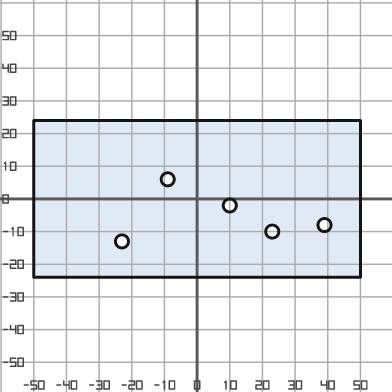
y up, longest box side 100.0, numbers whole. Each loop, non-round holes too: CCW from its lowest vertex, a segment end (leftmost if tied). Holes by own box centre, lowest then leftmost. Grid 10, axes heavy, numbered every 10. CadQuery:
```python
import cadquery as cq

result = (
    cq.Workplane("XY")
    .moveTo(-50.0, -24.0)
    .lineTo(50.0, -24.0)
    .lineTo(50.0, 24.0)
    .lineTo(-50.0, 24.0)
    .close()
    .moveTo(-23.0, -13.0)
    .circle(2.0)
    .moveTo(23.0, -10.0)
    .circle(2.0)
    .moveTo(39.0, -8.0)
    .circle(2.0)
    .moveTo(10.0, -2.0)
    .circle(2.0)
    .moveTo(-9.0, 6.0)
    .circle(2.0)
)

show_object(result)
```